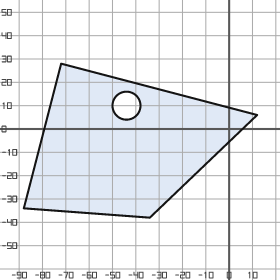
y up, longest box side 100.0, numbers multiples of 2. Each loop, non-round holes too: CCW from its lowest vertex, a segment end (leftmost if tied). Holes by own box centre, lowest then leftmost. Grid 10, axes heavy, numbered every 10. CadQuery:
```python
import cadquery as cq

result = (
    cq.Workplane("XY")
    .moveTo(-34.0, -38.0)
    .lineTo(12.0, 6.0)
    .lineTo(-72.0, 28.0)
    .lineTo(-88.0, -34.0)
    .close()
    .moveTo(-44.0, 10.0)
    .circle(6.0)
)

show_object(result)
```